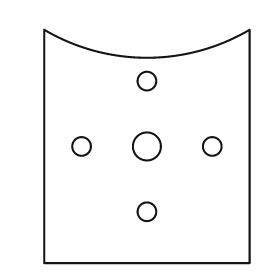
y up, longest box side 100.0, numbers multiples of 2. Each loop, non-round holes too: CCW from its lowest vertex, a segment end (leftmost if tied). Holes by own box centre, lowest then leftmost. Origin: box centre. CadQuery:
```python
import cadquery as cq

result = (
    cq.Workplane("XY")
    .moveTo(-44.0, -50.0)
    .lineTo(44.0, -50.0)
    .lineTo(44.0, 50.0)
    .threePointArc((0.0, 38.0), (-44.0, 50.0))
    .close()
    .moveTo(0.0, -28.0)
    .circle(4.0)
    .moveTo(-28.0, 0.0)
    .circle(4.0)
    .moveTo(0.0, 0.0)
    .circle(6.0)
    .moveTo(28.0, 0.0)
    .circle(4.0)
    .moveTo(0.0, 28.0)
    .circle(4.0)
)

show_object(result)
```